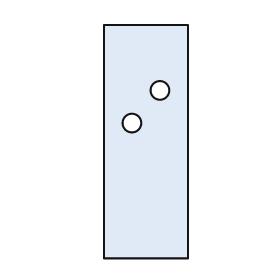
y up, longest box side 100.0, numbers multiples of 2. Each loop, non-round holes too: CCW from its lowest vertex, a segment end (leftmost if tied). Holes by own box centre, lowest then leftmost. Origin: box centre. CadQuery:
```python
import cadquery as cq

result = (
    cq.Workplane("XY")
    .moveTo(-18.0, -50.0)
    .lineTo(18.0, -50.0)
    .lineTo(18.0, 50.0)
    .lineTo(-18.0, 50.0)
    .close()
    .moveTo(-6.0, 8.0)
    .circle(4.0)
    .moveTo(6.0, 22.0)
    .circle(4.0)
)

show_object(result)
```